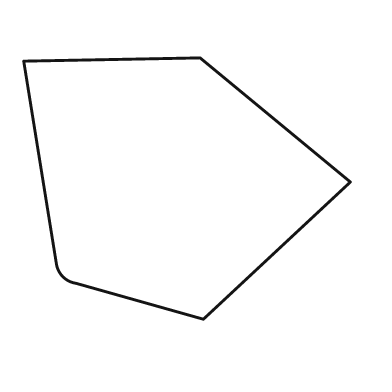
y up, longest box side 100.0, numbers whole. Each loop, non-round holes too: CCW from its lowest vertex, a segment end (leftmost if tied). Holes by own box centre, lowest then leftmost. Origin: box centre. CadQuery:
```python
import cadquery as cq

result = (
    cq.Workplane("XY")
    .moveTo(5.0, -40.0)
    .lineTo(50.0, 2.0)
    .lineTo(4.0, 40.0)
    .lineTo(-50.0, 39.0)
    .lineTo(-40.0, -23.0)
    .threePointArc((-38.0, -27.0), (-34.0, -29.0))
    .close()
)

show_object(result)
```